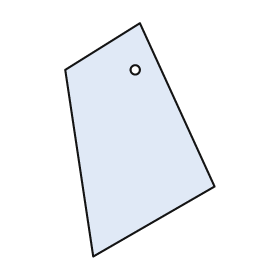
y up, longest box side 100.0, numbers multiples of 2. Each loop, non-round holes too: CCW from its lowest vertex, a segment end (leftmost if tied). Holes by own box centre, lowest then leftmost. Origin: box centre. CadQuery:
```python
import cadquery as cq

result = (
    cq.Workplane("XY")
    .moveTo(-20.0, -50.0)
    .lineTo(32.0, -20.0)
    .lineTo(0.0, 50.0)
    .lineTo(-32.0, 30.0)
    .close()
    .moveTo(-2.0, 30.0)
    .circle(2.0)
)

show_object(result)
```